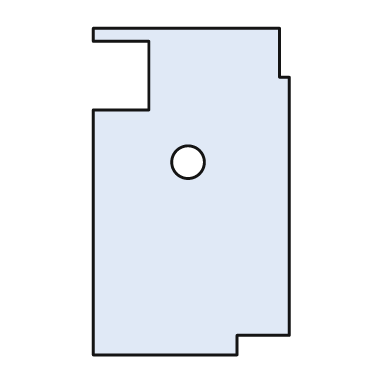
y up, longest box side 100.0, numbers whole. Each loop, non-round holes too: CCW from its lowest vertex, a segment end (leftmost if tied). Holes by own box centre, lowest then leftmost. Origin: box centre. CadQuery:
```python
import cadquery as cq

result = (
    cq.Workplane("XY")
    .moveTo(-30.0, -50.0)
    .lineTo(14.0, -50.0)
    .lineTo(14.0, -44.0)
    .lineTo(30.0, -44.0)
    .lineTo(30.0, 35.0)
    .lineTo(27.0, 35.0)
    .lineTo(27.0, 50.0)
    .lineTo(-30.0, 50.0)
    .lineTo(-30.0, 46.0)
    .lineTo(-13.0, 46.0)
    .lineTo(-13.0, 25.0)
    .lineTo(-30.0, 25.0)
    .close()
    .moveTo(-1.0, 9.0)
    .circle(5.0)
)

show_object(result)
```